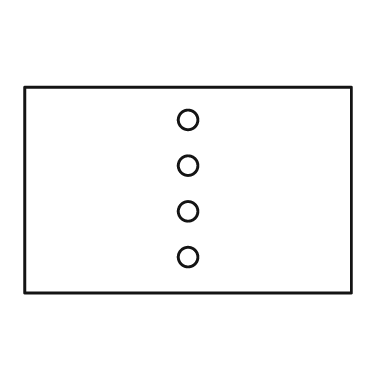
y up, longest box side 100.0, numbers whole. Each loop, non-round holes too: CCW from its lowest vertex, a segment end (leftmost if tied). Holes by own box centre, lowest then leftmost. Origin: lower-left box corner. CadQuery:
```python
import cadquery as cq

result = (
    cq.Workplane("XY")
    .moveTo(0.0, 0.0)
    .lineTo(100.0, 0.0)
    .lineTo(100.0, 63.0)
    .lineTo(0.0, 63.0)
    .close()
    .moveTo(50.0, 11.0)
    .circle(3.0)
    .moveTo(50.0, 25.0)
    .circle(3.0)
    .moveTo(50.0, 39.0)
    .circle(3.0)
    .moveTo(50.0, 53.0)
    .circle(3.0)
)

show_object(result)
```